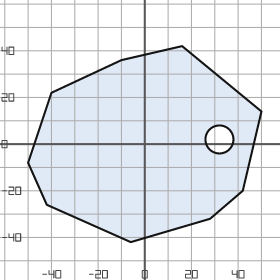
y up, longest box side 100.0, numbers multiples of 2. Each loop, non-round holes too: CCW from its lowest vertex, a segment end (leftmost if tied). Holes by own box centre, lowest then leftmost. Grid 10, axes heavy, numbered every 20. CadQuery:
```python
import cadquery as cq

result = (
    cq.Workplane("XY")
    .moveTo(-6.0, -42.0)
    .lineTo(28.0, -32.0)
    .lineTo(42.0, -20.0)
    .lineTo(50.0, 14.0)
    .lineTo(16.0, 42.0)
    .lineTo(-10.0, 36.0)
    .lineTo(-40.0, 22.0)
    .lineTo(-50.0, -8.0)
    .lineTo(-42.0, -26.0)
    .close()
    .moveTo(32.0, 2.0)
    .circle(6.0)
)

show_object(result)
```